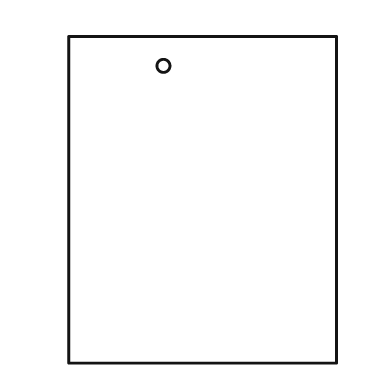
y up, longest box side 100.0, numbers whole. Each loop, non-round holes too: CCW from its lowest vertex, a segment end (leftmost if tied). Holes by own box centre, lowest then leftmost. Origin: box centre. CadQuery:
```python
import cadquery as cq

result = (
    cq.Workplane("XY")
    .moveTo(-41.0, -50.0)
    .lineTo(41.0, -50.0)
    .lineTo(41.0, 50.0)
    .lineTo(-41.0, 50.0)
    .close()
    .moveTo(-12.0, 41.0)
    .circle(2.0)
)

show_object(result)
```